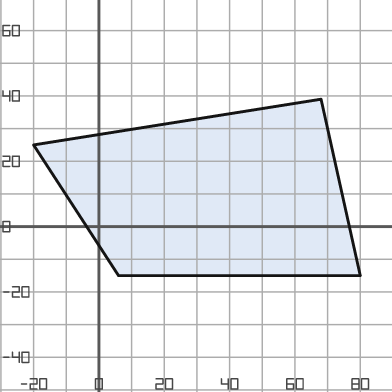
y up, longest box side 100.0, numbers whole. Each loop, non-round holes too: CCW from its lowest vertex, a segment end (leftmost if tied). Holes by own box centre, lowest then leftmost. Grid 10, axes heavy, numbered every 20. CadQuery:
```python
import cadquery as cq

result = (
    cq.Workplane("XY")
    .moveTo(6.0, -15.0)
    .lineTo(80.0, -15.0)
    .lineTo(68.0, 39.0)
    .lineTo(-20.0, 25.0)
    .close()
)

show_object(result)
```